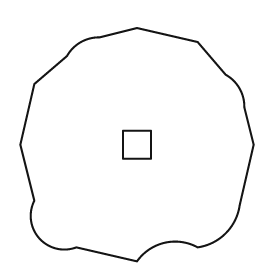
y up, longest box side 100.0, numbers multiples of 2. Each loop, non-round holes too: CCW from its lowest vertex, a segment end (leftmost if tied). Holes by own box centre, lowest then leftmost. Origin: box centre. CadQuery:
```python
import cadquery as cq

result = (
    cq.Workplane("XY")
    .moveTo(0.0, -50.0)
    .threePointArc((12.0, -42.0), (26.0, -44.0))
    .threePointArc((38.0, -38.0), (44.0, -26.0))
    .lineTo(50.0, 0.0)
    .lineTo(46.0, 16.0)
    .threePointArc((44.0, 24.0), (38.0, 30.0))
    .lineTo(26.0, 44.0)
    .lineTo(0.0, 50.0)
    .lineTo(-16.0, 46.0)
    .threePointArc((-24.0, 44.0), (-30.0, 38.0))
    .lineTo(-44.0, 26.0)
    .lineTo(-50.0, 0.0)
    .lineTo(-44.0, -24.0)
    .threePointArc((-42.0, -40.0), (-26.0, -44.0))
    .close()
    .moveTo(-6.0, -6.0)
    .lineTo(6.0, -6.0)
    .lineTo(6.0, 6.0)
    .lineTo(-6.0, 6.0)
    .close()
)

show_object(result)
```